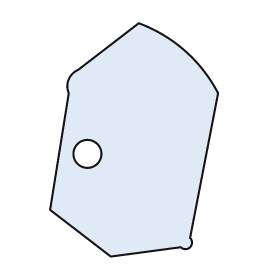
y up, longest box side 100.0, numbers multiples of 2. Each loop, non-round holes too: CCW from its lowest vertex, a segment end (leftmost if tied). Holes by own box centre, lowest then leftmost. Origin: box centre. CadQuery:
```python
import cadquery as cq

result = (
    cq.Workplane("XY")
    .moveTo(-10.0, -50.0)
    .lineTo(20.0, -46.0)
    .threePointArc((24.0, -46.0), (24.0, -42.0))
    .lineTo(36.0, 20.0)
    .threePointArc((22.0, 38.0), (2.0, 50.0))
    .lineTo(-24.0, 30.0)
    .threePointArc((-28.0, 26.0), (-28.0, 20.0))
    .lineTo(-36.0, -30.0)
    .close()
    .moveTo(-20.0, -6.0)
    .circle(6.0)
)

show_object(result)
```